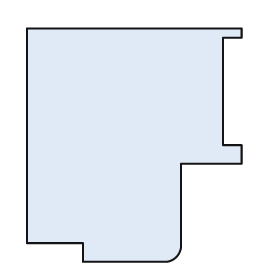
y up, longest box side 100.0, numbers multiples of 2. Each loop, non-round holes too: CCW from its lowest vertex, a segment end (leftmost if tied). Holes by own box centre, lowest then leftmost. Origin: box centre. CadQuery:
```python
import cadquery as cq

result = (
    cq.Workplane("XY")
    .moveTo(-22.0, -50.0)
    .lineTo(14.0, -50.0)
    .threePointArc((18.0, -48.0), (20.0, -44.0))
    .lineTo(20.0, -8.0)
    .lineTo(46.0, -8.0)
    .lineTo(46.0, 0.0)
    .lineTo(38.0, 0.0)
    .lineTo(38.0, 46.0)
    .lineTo(46.0, 46.0)
    .lineTo(46.0, 50.0)
    .lineTo(-46.0, 50.0)
    .lineTo(-46.0, -42.0)
    .lineTo(-22.0, -42.0)
    .close()
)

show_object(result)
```